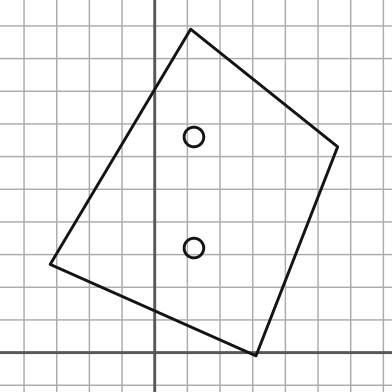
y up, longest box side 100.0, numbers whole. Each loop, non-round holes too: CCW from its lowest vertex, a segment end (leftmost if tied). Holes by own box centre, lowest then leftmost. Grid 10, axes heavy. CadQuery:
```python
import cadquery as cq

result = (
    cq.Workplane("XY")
    .moveTo(31.0, -1.0)
    .lineTo(56.0, 63.0)
    .lineTo(11.0, 99.0)
    .lineTo(-32.0, 27.0)
    .close()
    .moveTo(12.0, 32.0)
    .circle(3.0)
    .moveTo(12.0, 66.0)
    .circle(3.0)
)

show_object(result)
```